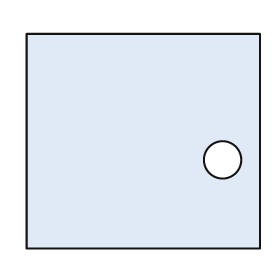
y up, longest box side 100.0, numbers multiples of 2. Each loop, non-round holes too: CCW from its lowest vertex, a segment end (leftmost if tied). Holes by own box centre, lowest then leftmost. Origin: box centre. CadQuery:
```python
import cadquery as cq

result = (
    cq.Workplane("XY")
    .moveTo(-50.0, -46.0)
    .lineTo(50.0, -46.0)
    .lineTo(50.0, 46.0)
    .lineTo(-50.0, 46.0)
    .close()
    .moveTo(34.0, -8.0)
    .circle(8.0)
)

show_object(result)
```